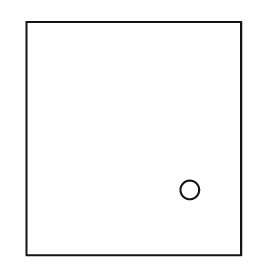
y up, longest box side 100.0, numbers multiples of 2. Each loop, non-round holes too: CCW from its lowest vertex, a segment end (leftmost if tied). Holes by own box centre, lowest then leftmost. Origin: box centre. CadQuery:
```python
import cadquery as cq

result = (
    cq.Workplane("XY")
    .moveTo(-46.0, -50.0)
    .lineTo(46.0, -50.0)
    .lineTo(46.0, 50.0)
    .lineTo(-46.0, 50.0)
    .close()
    .moveTo(24.0, -22.0)
    .circle(4.0)
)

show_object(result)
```